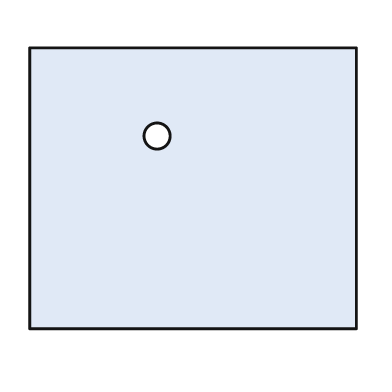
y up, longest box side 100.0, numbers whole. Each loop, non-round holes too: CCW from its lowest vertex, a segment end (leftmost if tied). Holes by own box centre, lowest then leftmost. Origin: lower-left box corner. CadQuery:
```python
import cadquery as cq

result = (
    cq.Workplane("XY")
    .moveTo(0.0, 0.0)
    .lineTo(100.0, 0.0)
    .lineTo(100.0, 86.0)
    .lineTo(0.0, 86.0)
    .close()
    .moveTo(39.0, 59.0)
    .circle(4.0)
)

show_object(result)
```